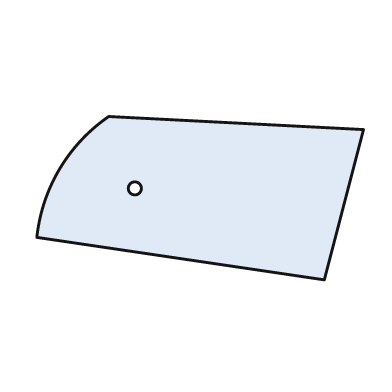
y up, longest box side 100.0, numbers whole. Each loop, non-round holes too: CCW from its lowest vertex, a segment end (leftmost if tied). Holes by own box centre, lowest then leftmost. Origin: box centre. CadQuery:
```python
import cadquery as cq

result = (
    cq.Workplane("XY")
    .moveTo(38.0, -25.0)
    .lineTo(50.0, 21.0)
    .lineTo(-28.0, 25.0)
    .threePointArc((-43.0, 9.0), (-50.0, -12.0))
    .close()
    .moveTo(-20.0, 3.0)
    .circle(2.0)
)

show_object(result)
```